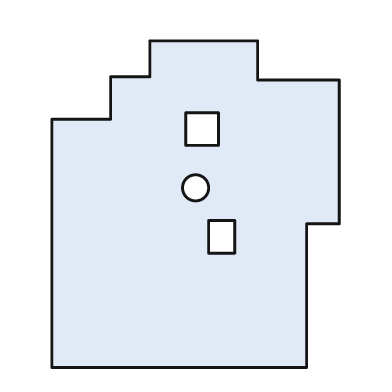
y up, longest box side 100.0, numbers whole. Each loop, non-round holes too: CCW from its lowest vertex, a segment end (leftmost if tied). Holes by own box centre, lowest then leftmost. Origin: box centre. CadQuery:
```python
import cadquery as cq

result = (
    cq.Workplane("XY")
    .moveTo(-44.0, -50.0)
    .lineTo(34.0, -50.0)
    .lineTo(34.0, -6.0)
    .lineTo(44.0, -6.0)
    .lineTo(44.0, 38.0)
    .lineTo(19.0, 38.0)
    .lineTo(19.0, 50.0)
    .lineTo(-14.0, 50.0)
    .lineTo(-14.0, 39.0)
    .lineTo(-26.0, 39.0)
    .lineTo(-26.0, 26.0)
    .lineTo(-44.0, 26.0)
    .close()
    .moveTo(4.0, -15.0)
    .lineTo(12.0, -15.0)
    .lineTo(12.0, -5.0)
    .lineTo(4.0, -5.0)
    .close()
    .moveTo(0.0, 5.0)
    .circle(4.0)
    .moveTo(-3.0, 18.0)
    .lineTo(7.0, 18.0)
    .lineTo(7.0, 28.0)
    .lineTo(-3.0, 28.0)
    .close()
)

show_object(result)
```